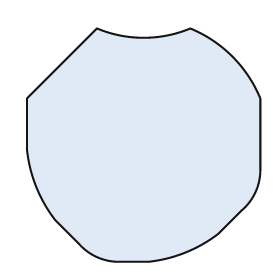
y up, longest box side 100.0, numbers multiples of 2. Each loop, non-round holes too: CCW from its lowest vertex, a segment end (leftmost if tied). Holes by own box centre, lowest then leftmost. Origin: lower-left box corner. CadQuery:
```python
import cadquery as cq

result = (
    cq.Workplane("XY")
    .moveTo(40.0, 0.0)
    .lineTo(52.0, 0.0)
    .threePointArc((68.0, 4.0), (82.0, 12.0))
    .lineTo(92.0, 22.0)
    .threePointArc((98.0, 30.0), (100.0, 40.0))
    .lineTo(100.0, 70.0)
    .threePointArc((88.0, 88.0), (70.0, 100.0))
    .threePointArc((50.0, 96.0), (30.0, 100.0))
    .lineTo(0.0, 70.0)
    .lineTo(0.0, 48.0)
    .threePointArc((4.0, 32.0), (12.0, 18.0))
    .lineTo(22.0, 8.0)
    .threePointArc((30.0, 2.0), (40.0, 0.0))
    .close()
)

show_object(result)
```